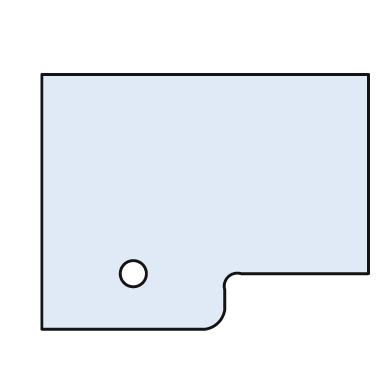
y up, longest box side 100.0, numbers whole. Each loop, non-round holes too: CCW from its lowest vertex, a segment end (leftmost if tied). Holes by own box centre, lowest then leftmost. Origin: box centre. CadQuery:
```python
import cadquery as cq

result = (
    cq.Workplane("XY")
    .moveTo(-50.0, -39.0)
    .lineTo(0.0, -39.0)
    .threePointArc((4.0, -37.0), (6.0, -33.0))
    .lineTo(6.0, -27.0)
    .threePointArc((7.0, -23.0), (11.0, -22.0))
    .lineTo(50.0, -22.0)
    .lineTo(50.0, 39.0)
    .lineTo(-50.0, 39.0)
    .close()
    .moveTo(-22.0, -22.0)
    .circle(4.0)
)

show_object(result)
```